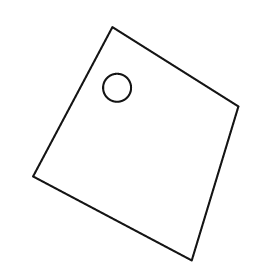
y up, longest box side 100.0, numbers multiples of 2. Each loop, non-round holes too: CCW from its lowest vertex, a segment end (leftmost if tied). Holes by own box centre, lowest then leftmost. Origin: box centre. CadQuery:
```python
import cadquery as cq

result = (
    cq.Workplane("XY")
    .moveTo(24.0, -50.0)
    .lineTo(44.0, 16.0)
    .lineTo(-10.0, 50.0)
    .lineTo(-44.0, -14.0)
    .close()
    .moveTo(-8.0, 24.0)
    .circle(6.0)
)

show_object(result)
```